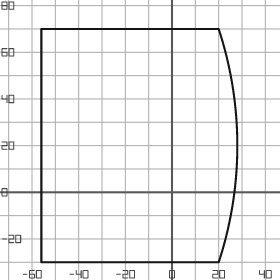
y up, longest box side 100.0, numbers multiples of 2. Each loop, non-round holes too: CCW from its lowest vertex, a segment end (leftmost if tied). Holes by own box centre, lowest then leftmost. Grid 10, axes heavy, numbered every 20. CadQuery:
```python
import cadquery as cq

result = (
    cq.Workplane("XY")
    .moveTo(-56.0, -30.0)
    .lineTo(20.0, -30.0)
    .threePointArc((28.0, 20.0), (20.0, 70.0))
    .lineTo(-56.0, 70.0)
    .close()
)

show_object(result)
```